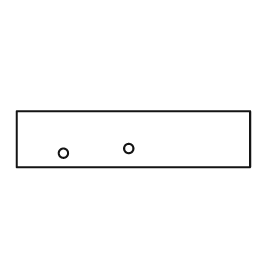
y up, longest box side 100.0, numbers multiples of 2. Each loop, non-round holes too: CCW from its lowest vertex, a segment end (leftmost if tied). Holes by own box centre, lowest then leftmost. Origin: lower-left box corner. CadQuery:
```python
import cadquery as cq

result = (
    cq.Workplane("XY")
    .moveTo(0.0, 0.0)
    .lineTo(100.0, 0.0)
    .lineTo(100.0, 24.0)
    .lineTo(0.0, 24.0)
    .close()
    .moveTo(20.0, 6.0)
    .circle(2.0)
    .moveTo(48.0, 8.0)
    .circle(2.0)
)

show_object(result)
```